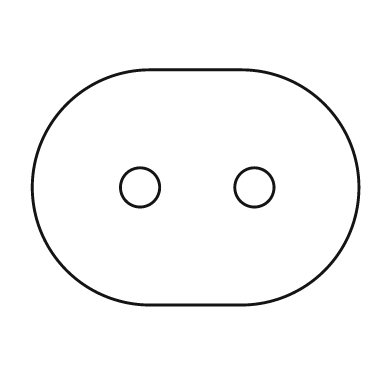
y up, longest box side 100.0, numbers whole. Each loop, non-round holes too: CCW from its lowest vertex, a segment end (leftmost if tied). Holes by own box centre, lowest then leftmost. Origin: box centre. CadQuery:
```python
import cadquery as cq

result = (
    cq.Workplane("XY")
    .moveTo(-14.0, -36.0)
    .lineTo(14.0, -36.0)
    .threePointArc((50.0, 0.0), (14.0, 36.0))
    .lineTo(-14.0, 36.0)
    .threePointArc((-50.0, 0.0), (-14.0, -36.0))
    .close()
    .moveTo(-17.0, 0.0)
    .circle(6.0)
    .moveTo(18.0, 0.0)
    .circle(6.0)
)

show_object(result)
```